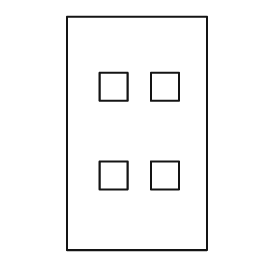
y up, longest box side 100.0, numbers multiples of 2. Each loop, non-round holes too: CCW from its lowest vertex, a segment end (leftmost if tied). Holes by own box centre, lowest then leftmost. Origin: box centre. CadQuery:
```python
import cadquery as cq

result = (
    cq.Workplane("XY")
    .moveTo(-30.0, -50.0)
    .lineTo(30.0, -50.0)
    .lineTo(30.0, 50.0)
    .lineTo(-30.0, 50.0)
    .close()
    .moveTo(-16.0, -24.0)
    .lineTo(-4.0, -24.0)
    .lineTo(-4.0, -12.0)
    .lineTo(-16.0, -12.0)
    .close()
    .moveTo(6.0, -24.0)
    .lineTo(18.0, -24.0)
    .lineTo(18.0, -12.0)
    .lineTo(6.0, -12.0)
    .close()
    .moveTo(-16.0, 14.0)
    .lineTo(-4.0, 14.0)
    .lineTo(-4.0, 26.0)
    .lineTo(-16.0, 26.0)
    .close()
    .moveTo(6.0, 14.0)
    .lineTo(18.0, 14.0)
    .lineTo(18.0, 26.0)
    .lineTo(6.0, 26.0)
    .close()
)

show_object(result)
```